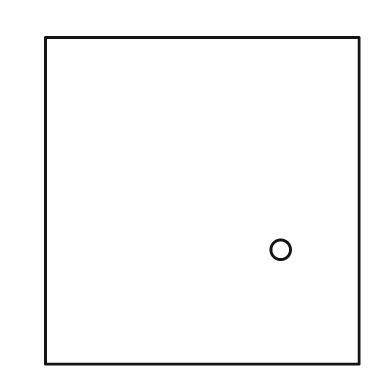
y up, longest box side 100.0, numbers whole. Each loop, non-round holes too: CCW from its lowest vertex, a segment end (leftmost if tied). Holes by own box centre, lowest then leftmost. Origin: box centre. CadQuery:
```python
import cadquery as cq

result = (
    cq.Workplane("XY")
    .moveTo(-48.0, -50.0)
    .lineTo(48.0, -50.0)
    .lineTo(48.0, 50.0)
    .lineTo(-48.0, 50.0)
    .close()
    .moveTo(24.0, -15.0)
    .circle(3.0)
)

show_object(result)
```